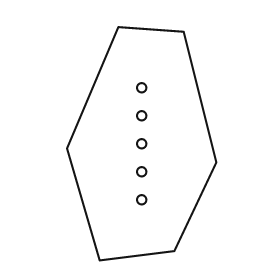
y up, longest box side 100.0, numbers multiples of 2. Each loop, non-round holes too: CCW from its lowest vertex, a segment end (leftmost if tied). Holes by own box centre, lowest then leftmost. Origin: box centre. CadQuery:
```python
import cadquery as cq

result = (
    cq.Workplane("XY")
    .moveTo(-18.0, -50.0)
    .lineTo(14.0, -46.0)
    .lineTo(32.0, -8.0)
    .lineTo(18.0, 48.0)
    .lineTo(-10.0, 50.0)
    .lineTo(-32.0, -2.0)
    .close()
    .moveTo(0.0, -24.0)
    .circle(2.0)
    .moveTo(0.0, -12.0)
    .circle(2.0)
    .moveTo(0.0, 0.0)
    .circle(2.0)
    .moveTo(0.0, 12.0)
    .circle(2.0)
    .moveTo(0.0, 24.0)
    .circle(2.0)
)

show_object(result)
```